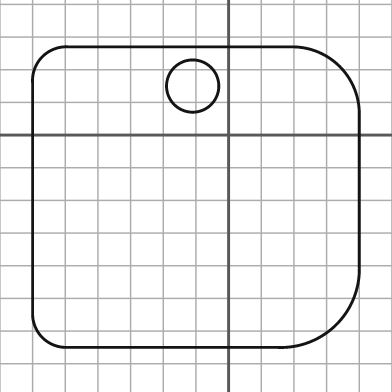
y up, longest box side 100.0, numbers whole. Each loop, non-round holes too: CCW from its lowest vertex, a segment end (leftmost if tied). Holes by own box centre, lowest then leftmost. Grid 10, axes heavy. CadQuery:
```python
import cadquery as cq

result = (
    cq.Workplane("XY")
    .moveTo(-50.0, -65.0)
    .lineTo(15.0, -65.0)
    .threePointArc((33.0, -58.0), (40.0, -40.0))
    .lineTo(40.0, 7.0)
    .threePointArc((34.0, 21.0), (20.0, 27.0))
    .lineTo(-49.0, 27.0)
    .threePointArc((-57.0, 24.0), (-60.0, 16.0))
    .lineTo(-60.0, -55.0)
    .threePointArc((-57.0, -62.0), (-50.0, -65.0))
    .close()
    .moveTo(-11.0, 15.0)
    .circle(8.0)
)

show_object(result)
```